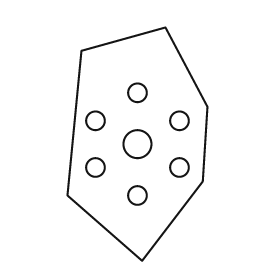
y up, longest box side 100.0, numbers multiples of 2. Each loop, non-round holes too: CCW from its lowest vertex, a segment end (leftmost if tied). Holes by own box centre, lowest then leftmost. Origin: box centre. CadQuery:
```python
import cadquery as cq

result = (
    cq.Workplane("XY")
    .moveTo(2.0, -50.0)
    .lineTo(28.0, -16.0)
    .lineTo(30.0, 16.0)
    .lineTo(12.0, 50.0)
    .lineTo(-24.0, 40.0)
    .lineTo(-30.0, -22.0)
    .close()
    .moveTo(0.0, -22.0)
    .circle(4.0)
    .moveTo(-18.0, -10.0)
    .circle(4.0)
    .moveTo(18.0, -10.0)
    .circle(4.0)
    .moveTo(0.0, 0.0)
    .circle(6.0)
    .moveTo(-18.0, 10.0)
    .circle(4.0)
    .moveTo(18.0, 10.0)
    .circle(4.0)
    .moveTo(0.0, 22.0)
    .circle(4.0)
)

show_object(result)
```